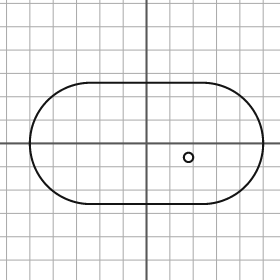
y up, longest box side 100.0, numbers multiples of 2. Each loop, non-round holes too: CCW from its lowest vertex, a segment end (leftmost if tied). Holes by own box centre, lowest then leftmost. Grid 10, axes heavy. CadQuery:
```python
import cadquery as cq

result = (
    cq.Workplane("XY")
    .moveTo(-24.0, -26.0)
    .lineTo(24.0, -26.0)
    .threePointArc((50.0, 0.0), (24.0, 26.0))
    .lineTo(-24.0, 26.0)
    .threePointArc((-50.0, 0.0), (-24.0, -26.0))
    .close()
    .moveTo(18.0, -6.0)
    .circle(2.0)
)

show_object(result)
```